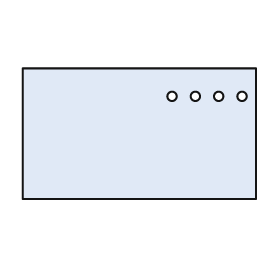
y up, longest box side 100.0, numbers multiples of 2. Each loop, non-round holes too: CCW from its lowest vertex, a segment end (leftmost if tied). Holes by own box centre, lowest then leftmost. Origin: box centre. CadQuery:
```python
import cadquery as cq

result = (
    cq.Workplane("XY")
    .moveTo(-50.0, -28.0)
    .lineTo(50.0, -28.0)
    .lineTo(50.0, 28.0)
    .lineTo(-50.0, 28.0)
    .close()
    .moveTo(14.0, 16.0)
    .circle(2.0)
    .moveTo(24.0, 16.0)
    .circle(2.0)
    .moveTo(34.0, 16.0)
    .circle(2.0)
    .moveTo(44.0, 16.0)
    .circle(2.0)
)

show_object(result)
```